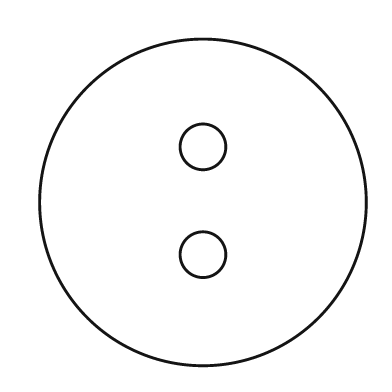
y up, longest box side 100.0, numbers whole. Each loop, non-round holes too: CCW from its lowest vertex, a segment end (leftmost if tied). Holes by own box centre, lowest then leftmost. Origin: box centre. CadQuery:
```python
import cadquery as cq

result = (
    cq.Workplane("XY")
    .moveTo(0.0, 0.0)
    .circle(50.0)
    .moveTo(0.0, -16.0)
    .circle(7.0)
    .moveTo(0.0, 17.0)
    .circle(7.0)
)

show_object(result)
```